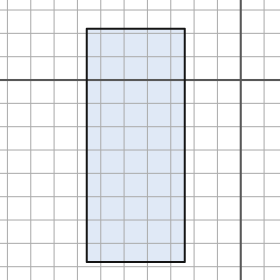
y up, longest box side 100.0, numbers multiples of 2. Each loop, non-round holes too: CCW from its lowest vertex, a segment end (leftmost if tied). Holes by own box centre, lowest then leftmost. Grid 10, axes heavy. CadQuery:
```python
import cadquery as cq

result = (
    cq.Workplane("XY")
    .moveTo(-66.0, -78.0)
    .lineTo(-24.0, -78.0)
    .lineTo(-24.0, 22.0)
    .lineTo(-66.0, 22.0)
    .close()
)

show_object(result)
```